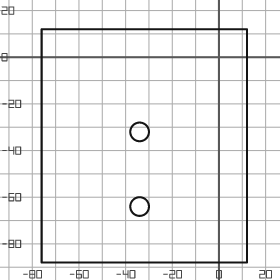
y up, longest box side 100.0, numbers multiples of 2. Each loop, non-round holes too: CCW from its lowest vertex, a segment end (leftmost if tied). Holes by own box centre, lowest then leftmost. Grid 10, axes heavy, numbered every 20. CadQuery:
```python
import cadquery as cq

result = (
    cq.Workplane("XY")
    .moveTo(-76.0, -88.0)
    .lineTo(12.0, -88.0)
    .lineTo(12.0, 12.0)
    .lineTo(-76.0, 12.0)
    .close()
    .moveTo(-34.0, -64.0)
    .circle(4.0)
    .moveTo(-34.0, -32.0)
    .circle(4.0)
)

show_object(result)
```